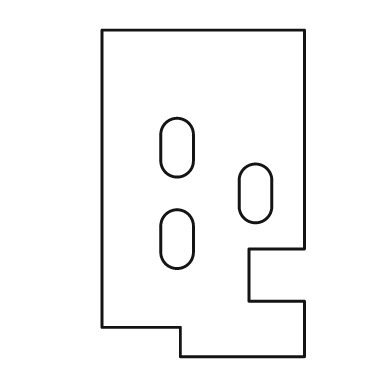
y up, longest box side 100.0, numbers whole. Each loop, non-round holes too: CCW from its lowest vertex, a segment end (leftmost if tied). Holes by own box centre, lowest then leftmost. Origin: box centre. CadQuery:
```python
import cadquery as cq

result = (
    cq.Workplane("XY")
    .moveTo(-7.0, -50.0)
    .lineTo(31.0, -50.0)
    .lineTo(31.0, -33.0)
    .lineTo(14.0, -33.0)
    .lineTo(14.0, -17.0)
    .lineTo(31.0, -17.0)
    .lineTo(31.0, 50.0)
    .lineTo(-31.0, 50.0)
    .lineTo(-31.0, -41.0)
    .lineTo(-7.0, -41.0)
    .close()
    .moveTo(-13.0, -18.0)
    .threePointArc((-8.0, -23.0), (-3.0, -18.0))
    .lineTo(-3.0, -10.0)
    .threePointArc((-8.0, -5.0), (-13.0, -10.0))
    .close()
    .moveTo(11.0, -4.0)
    .threePointArc((16.0, -9.0), (21.0, -4.0))
    .lineTo(21.0, 4.0)
    .threePointArc((16.0, 9.0), (11.0, 4.0))
    .close()
    .moveTo(-13.0, 10.0)
    .threePointArc((-8.0, 5.0), (-3.0, 10.0))
    .lineTo(-3.0, 18.0)
    .threePointArc((-8.0, 23.0), (-13.0, 18.0))
    .close()
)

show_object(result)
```